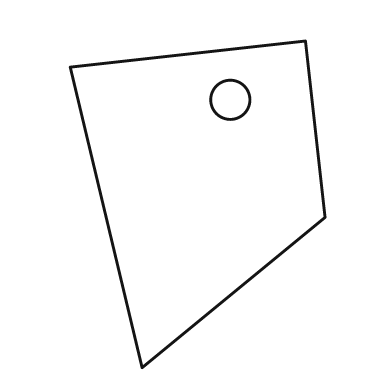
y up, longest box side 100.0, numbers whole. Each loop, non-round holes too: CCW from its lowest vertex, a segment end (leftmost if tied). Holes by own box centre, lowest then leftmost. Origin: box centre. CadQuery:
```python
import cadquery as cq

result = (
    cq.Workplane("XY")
    .moveTo(-17.0, -50.0)
    .lineTo(39.0, -4.0)
    .lineTo(33.0, 50.0)
    .lineTo(-39.0, 42.0)
    .close()
    .moveTo(10.0, 32.0)
    .circle(6.0)
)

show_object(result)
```